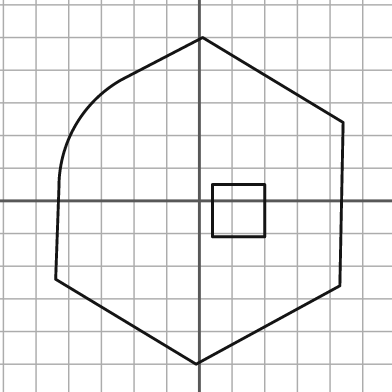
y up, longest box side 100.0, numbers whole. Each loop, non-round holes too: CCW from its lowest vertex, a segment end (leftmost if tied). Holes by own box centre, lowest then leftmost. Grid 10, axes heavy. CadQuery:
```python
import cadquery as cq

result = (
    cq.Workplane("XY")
    .moveTo(-1.0, -50.0)
    .lineTo(43.0, -26.0)
    .lineTo(44.0, 24.0)
    .lineTo(1.0, 50.0)
    .lineTo(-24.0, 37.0)
    .threePointArc((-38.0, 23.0), (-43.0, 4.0))
    .lineTo(-44.0, -24.0)
    .close()
    .moveTo(4.0, -11.0)
    .lineTo(20.0, -11.0)
    .lineTo(20.0, 5.0)
    .lineTo(4.0, 5.0)
    .close()
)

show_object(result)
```